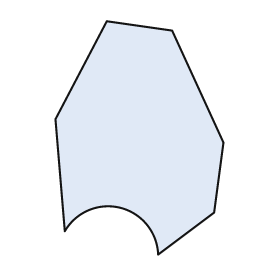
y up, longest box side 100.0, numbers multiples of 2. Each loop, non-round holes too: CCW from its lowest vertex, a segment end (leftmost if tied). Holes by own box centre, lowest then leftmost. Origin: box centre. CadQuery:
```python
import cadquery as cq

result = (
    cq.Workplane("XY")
    .moveTo(8.0, -50.0)
    .lineTo(32.0, -32.0)
    .lineTo(36.0, -2.0)
    .lineTo(14.0, 46.0)
    .lineTo(-14.0, 50.0)
    .lineTo(-36.0, 8.0)
    .lineTo(-32.0, -40.0)
    .threePointArc((-8.0, -30.0), (8.0, -50.0))
    .close()
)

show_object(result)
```